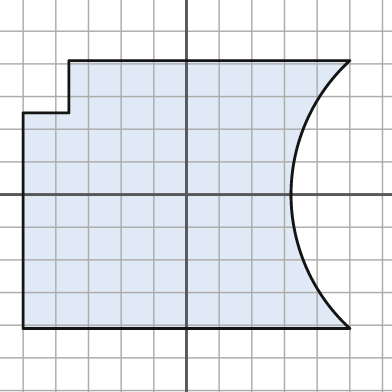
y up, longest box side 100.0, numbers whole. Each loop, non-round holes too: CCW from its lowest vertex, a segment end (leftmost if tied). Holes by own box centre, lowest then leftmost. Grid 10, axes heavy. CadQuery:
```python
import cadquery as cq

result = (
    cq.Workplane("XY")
    .moveTo(-50.0, -41.0)
    .lineTo(50.0, -41.0)
    .threePointArc((32.0, 0.0), (50.0, 41.0))
    .lineTo(-36.0, 41.0)
    .lineTo(-36.0, 25.0)
    .lineTo(-50.0, 25.0)
    .close()
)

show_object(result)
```